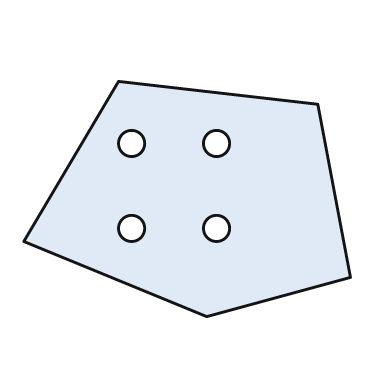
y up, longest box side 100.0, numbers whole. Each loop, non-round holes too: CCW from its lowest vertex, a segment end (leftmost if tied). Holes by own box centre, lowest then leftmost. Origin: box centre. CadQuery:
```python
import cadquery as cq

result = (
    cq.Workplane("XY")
    .moveTo(6.0, -36.0)
    .lineTo(50.0, -24.0)
    .lineTo(40.0, 29.0)
    .lineTo(-21.0, 36.0)
    .lineTo(-50.0, -13.0)
    .close()
    .moveTo(-17.0, -9.0)
    .circle(4.0)
    .moveTo(9.0, -9.0)
    .circle(4.0)
    .moveTo(-17.0, 17.0)
    .circle(4.0)
    .moveTo(9.0, 17.0)
    .circle(4.0)
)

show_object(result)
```